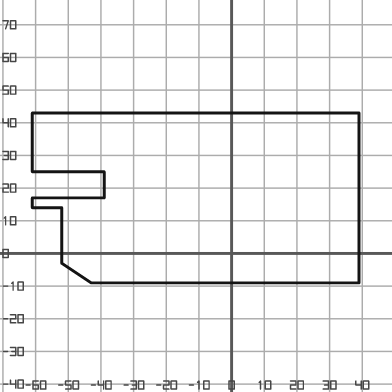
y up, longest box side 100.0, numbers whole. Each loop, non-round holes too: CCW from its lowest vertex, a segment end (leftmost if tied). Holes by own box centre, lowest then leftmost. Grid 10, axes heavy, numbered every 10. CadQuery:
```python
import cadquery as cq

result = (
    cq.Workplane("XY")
    .moveTo(-43.0, -9.0)
    .lineTo(39.0, -9.0)
    .lineTo(39.0, 43.0)
    .lineTo(-61.0, 43.0)
    .lineTo(-61.0, 25.0)
    .lineTo(-39.0, 25.0)
    .lineTo(-39.0, 17.0)
    .lineTo(-61.0, 17.0)
    .lineTo(-61.0, 14.0)
    .lineTo(-52.0, 14.0)
    .lineTo(-52.0, -3.0)
    .close()
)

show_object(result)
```